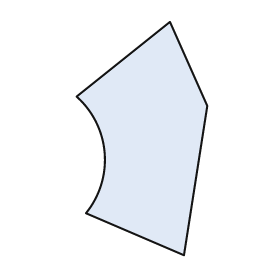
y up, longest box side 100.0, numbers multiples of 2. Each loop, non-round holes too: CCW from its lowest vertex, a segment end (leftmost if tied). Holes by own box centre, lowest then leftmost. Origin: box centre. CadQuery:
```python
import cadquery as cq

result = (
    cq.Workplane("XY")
    .moveTo(18.0, -50.0)
    .lineTo(28.0, 14.0)
    .lineTo(12.0, 50.0)
    .lineTo(-28.0, 18.0)
    .threePointArc((-16.0, -6.0), (-24.0, -32.0))
    .close()
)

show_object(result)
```